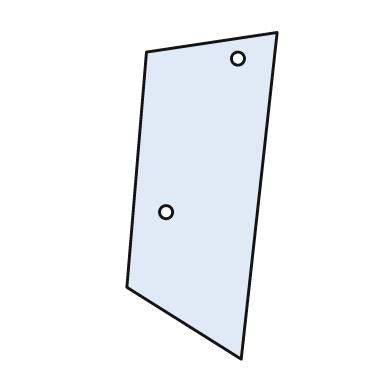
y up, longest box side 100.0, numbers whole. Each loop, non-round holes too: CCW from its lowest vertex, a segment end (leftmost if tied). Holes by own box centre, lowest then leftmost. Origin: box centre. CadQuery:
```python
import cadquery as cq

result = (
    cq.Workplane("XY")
    .moveTo(12.0, -50.0)
    .lineTo(23.0, 50.0)
    .lineTo(-17.0, 44.0)
    .lineTo(-23.0, -28.0)
    .close()
    .moveTo(-11.0, -5.0)
    .circle(2.0)
    .moveTo(11.0, 42.0)
    .circle(2.0)
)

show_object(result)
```